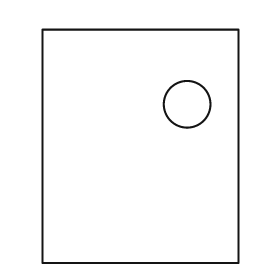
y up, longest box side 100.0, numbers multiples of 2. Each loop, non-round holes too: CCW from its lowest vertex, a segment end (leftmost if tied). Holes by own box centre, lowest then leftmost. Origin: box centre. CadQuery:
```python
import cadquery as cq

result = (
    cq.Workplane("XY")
    .moveTo(-42.0, -50.0)
    .lineTo(42.0, -50.0)
    .lineTo(42.0, 50.0)
    .lineTo(-42.0, 50.0)
    .close()
    .moveTo(20.0, 18.0)
    .circle(10.0)
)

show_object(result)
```